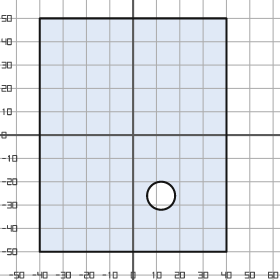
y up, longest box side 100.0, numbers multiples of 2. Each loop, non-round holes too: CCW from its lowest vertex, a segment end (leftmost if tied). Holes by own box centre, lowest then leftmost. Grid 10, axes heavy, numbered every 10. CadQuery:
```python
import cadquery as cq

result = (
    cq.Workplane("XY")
    .moveTo(-40.0, -50.0)
    .lineTo(40.0, -50.0)
    .lineTo(40.0, 50.0)
    .lineTo(-40.0, 50.0)
    .close()
    .moveTo(12.0, -26.0)
    .circle(6.0)
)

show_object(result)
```